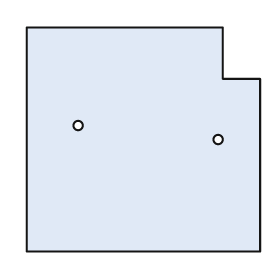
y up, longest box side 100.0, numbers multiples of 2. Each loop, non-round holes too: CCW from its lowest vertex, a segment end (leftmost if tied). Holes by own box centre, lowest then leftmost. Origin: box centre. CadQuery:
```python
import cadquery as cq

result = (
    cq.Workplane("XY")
    .moveTo(-50.0, -48.0)
    .lineTo(50.0, -48.0)
    .lineTo(50.0, 26.0)
    .lineTo(34.0, 26.0)
    .lineTo(34.0, 48.0)
    .lineTo(-50.0, 48.0)
    .close()
    .moveTo(32.0, 0.0)
    .circle(2.0)
    .moveTo(-28.0, 6.0)
    .circle(2.0)
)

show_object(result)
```